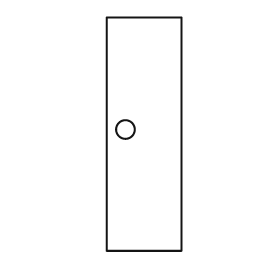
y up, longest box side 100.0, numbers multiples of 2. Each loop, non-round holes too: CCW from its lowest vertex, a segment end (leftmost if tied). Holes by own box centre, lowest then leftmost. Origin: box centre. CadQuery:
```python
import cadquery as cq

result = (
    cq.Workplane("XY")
    .moveTo(-16.0, -50.0)
    .lineTo(16.0, -50.0)
    .lineTo(16.0, 50.0)
    .lineTo(-16.0, 50.0)
    .close()
    .moveTo(-8.0, 2.0)
    .circle(4.0)
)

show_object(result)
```